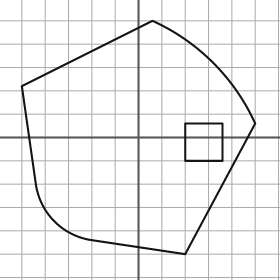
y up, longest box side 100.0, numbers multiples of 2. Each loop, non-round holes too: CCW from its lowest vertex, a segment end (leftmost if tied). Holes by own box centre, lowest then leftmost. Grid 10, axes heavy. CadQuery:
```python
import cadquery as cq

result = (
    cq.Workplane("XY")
    .moveTo(20.0, -50.0)
    .lineTo(50.0, 6.0)
    .threePointArc((32.0, 32.0), (6.0, 50.0))
    .lineTo(-50.0, 22.0)
    .lineTo(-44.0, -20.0)
    .threePointArc((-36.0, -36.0), (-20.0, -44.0))
    .close()
    .moveTo(20.0, -10.0)
    .lineTo(36.0, -10.0)
    .lineTo(36.0, 6.0)
    .lineTo(20.0, 6.0)
    .close()
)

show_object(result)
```